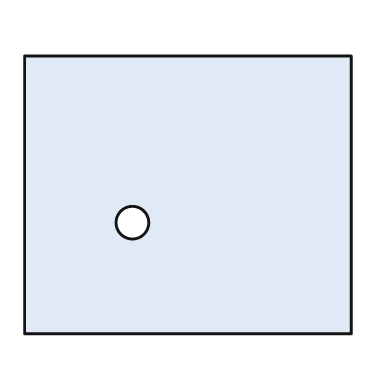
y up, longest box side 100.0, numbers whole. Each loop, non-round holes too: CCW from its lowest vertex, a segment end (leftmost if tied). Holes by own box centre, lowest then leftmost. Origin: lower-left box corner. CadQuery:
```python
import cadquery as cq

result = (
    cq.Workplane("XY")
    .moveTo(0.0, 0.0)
    .lineTo(100.0, 0.0)
    .lineTo(100.0, 85.0)
    .lineTo(0.0, 85.0)
    .close()
    .moveTo(33.0, 34.0)
    .circle(5.0)
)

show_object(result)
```